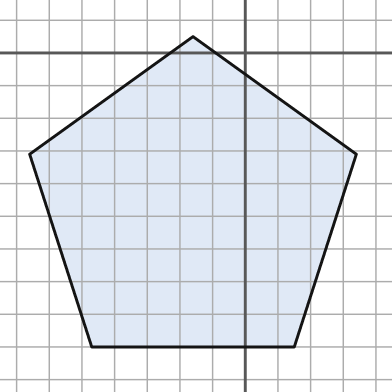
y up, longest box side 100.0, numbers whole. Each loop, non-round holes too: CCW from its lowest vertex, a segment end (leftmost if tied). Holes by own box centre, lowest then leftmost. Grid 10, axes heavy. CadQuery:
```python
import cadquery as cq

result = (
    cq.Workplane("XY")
    .moveTo(-47.0, -90.0)
    .lineTo(15.0, -90.0)
    .lineTo(34.0, -31.0)
    .lineTo(-16.0, 5.0)
    .lineTo(-66.0, -31.0)
    .close()
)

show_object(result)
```